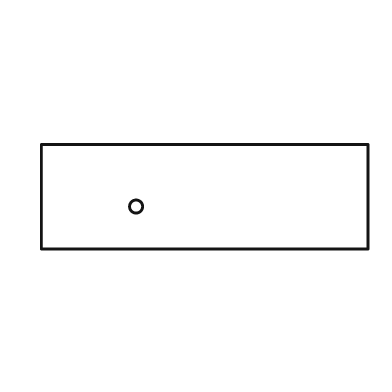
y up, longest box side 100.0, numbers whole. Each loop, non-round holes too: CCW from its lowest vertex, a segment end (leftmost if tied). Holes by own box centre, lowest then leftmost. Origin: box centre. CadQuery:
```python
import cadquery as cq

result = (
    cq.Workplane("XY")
    .moveTo(-50.0, -16.0)
    .lineTo(50.0, -16.0)
    .lineTo(50.0, 16.0)
    .lineTo(-50.0, 16.0)
    .close()
    .moveTo(-21.0, -3.0)
    .circle(2.0)
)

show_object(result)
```